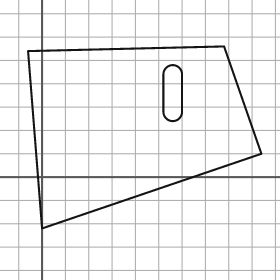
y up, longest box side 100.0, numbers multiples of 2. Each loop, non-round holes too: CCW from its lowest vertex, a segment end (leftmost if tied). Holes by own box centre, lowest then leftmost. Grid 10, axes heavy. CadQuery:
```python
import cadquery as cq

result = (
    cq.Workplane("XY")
    .moveTo(0.0, -22.0)
    .lineTo(94.0, 10.0)
    .lineTo(78.0, 56.0)
    .lineTo(-6.0, 54.0)
    .close()
    .moveTo(52.0, 28.0)
    .threePointArc((56.0, 24.0), (60.0, 28.0))
    .lineTo(60.0, 44.0)
    .threePointArc((56.0, 48.0), (52.0, 44.0))
    .close()
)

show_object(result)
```